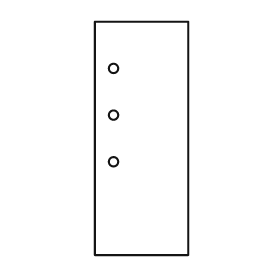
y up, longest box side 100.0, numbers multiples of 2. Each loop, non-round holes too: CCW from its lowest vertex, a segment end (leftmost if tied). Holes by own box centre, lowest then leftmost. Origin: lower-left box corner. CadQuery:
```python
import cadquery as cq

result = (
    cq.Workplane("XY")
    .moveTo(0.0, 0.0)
    .lineTo(40.0, 0.0)
    .lineTo(40.0, 100.0)
    .lineTo(0.0, 100.0)
    .close()
    .moveTo(8.0, 40.0)
    .circle(2.0)
    .moveTo(8.0, 60.0)
    .circle(2.0)
    .moveTo(8.0, 80.0)
    .circle(2.0)
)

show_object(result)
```